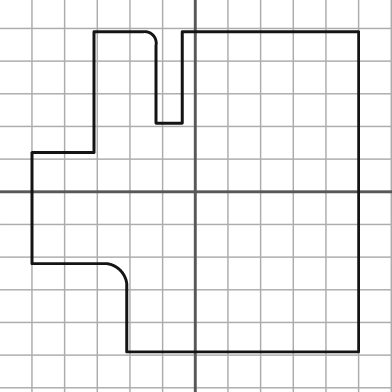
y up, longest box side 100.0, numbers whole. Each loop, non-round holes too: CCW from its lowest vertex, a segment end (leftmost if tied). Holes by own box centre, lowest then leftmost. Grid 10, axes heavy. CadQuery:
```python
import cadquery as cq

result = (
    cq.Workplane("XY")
    .moveTo(-21.0, -49.0)
    .lineTo(50.0, -49.0)
    .lineTo(50.0, 49.0)
    .lineTo(-4.0, 49.0)
    .lineTo(-4.0, 21.0)
    .lineTo(-12.0, 21.0)
    .lineTo(-12.0, 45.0)
    .threePointArc((-13.0, 48.0), (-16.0, 49.0))
    .lineTo(-31.0, 49.0)
    .lineTo(-31.0, 12.0)
    .lineTo(-50.0, 12.0)
    .lineTo(-50.0, -22.0)
    .lineTo(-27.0, -22.0)
    .threePointArc((-23.0, -24.0), (-21.0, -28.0))
    .close()
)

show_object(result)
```